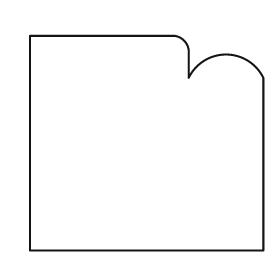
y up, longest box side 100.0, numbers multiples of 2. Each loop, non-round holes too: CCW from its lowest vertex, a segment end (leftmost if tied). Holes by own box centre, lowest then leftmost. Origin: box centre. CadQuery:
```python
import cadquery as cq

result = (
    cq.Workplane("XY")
    .moveTo(-50.0, -46.0)
    .lineTo(50.0, -46.0)
    .lineTo(50.0, 28.0)
    .threePointArc((34.0, 38.0), (18.0, 28.0))
    .lineTo(18.0, 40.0)
    .threePointArc((16.0, 44.0), (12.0, 46.0))
    .lineTo(-50.0, 46.0)
    .close()
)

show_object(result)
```